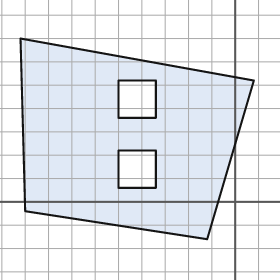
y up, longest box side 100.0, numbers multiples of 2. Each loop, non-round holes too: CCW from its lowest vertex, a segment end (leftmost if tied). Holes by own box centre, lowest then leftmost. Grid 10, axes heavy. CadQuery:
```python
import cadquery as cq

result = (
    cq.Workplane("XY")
    .moveTo(-12.0, -16.0)
    .lineTo(8.0, 52.0)
    .lineTo(-92.0, 70.0)
    .lineTo(-90.0, -4.0)
    .close()
    .moveTo(-50.0, 6.0)
    .lineTo(-34.0, 6.0)
    .lineTo(-34.0, 22.0)
    .lineTo(-50.0, 22.0)
    .close()
    .moveTo(-50.0, 36.0)
    .lineTo(-34.0, 36.0)
    .lineTo(-34.0, 52.0)
    .lineTo(-50.0, 52.0)
    .close()
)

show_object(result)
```